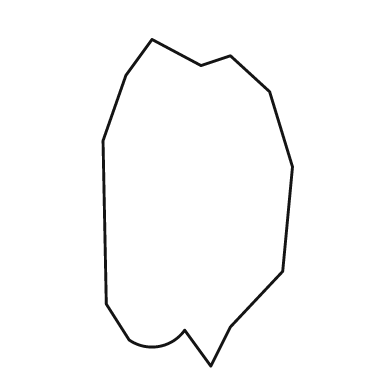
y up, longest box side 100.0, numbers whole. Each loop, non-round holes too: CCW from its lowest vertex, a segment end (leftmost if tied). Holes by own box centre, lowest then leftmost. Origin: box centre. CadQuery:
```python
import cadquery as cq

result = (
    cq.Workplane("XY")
    .moveTo(4.0, -50.0)
    .lineTo(10.0, -38.0)
    .lineTo(26.0, -21.0)
    .lineTo(29.0, 11.0)
    .lineTo(22.0, 34.0)
    .lineTo(10.0, 45.0)
    .lineTo(1.0, 42.0)
    .lineTo(-14.0, 50.0)
    .lineTo(-22.0, 39.0)
    .lineTo(-29.0, 19.0)
    .lineTo(-28.0, -31.0)
    .lineTo(-21.0, -42.0)
    .threePointArc((-12.0, -44.0), (-4.0, -39.0))
    .close()
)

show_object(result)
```